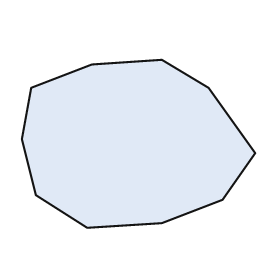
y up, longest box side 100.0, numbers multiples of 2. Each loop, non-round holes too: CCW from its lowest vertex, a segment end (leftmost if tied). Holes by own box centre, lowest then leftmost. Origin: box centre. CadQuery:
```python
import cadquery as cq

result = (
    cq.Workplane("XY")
    .moveTo(-22.0, -36.0)
    .lineTo(10.0, -34.0)
    .lineTo(36.0, -24.0)
    .lineTo(50.0, -4.0)
    .lineTo(30.0, 24.0)
    .lineTo(10.0, 36.0)
    .lineTo(-20.0, 34.0)
    .lineTo(-46.0, 24.0)
    .lineTo(-50.0, 2.0)
    .lineTo(-44.0, -22.0)
    .close()
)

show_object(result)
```